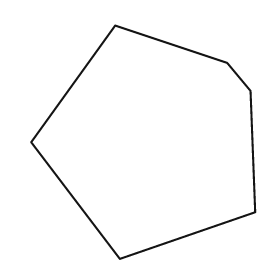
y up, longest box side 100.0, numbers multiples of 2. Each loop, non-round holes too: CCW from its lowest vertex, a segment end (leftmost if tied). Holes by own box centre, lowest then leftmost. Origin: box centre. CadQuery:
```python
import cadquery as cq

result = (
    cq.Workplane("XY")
    .moveTo(-10.0, -50.0)
    .lineTo(48.0, -30.0)
    .lineTo(46.0, 22.0)
    .lineTo(36.0, 34.0)
    .lineTo(-12.0, 50.0)
    .lineTo(-48.0, 0.0)
    .close()
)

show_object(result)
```